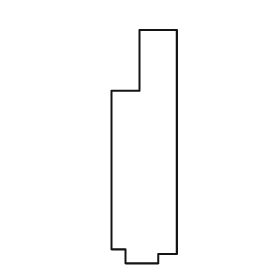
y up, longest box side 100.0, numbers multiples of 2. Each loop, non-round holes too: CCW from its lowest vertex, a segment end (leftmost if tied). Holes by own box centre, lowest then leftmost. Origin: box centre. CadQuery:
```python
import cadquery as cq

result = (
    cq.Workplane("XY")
    .moveTo(-8.0, -50.0)
    .lineTo(6.0, -50.0)
    .lineTo(6.0, -46.0)
    .lineTo(14.0, -46.0)
    .lineTo(14.0, 50.0)
    .lineTo(-2.0, 50.0)
    .lineTo(-2.0, 24.0)
    .lineTo(-14.0, 24.0)
    .lineTo(-14.0, -44.0)
    .lineTo(-8.0, -44.0)
    .close()
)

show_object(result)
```